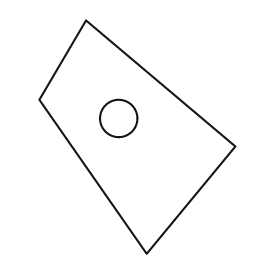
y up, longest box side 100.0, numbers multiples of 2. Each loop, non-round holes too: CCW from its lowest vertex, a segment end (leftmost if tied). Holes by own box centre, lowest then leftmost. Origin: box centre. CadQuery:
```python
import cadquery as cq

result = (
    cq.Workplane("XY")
    .moveTo(4.0, -50.0)
    .lineTo(42.0, -4.0)
    .lineTo(-22.0, 50.0)
    .lineTo(-42.0, 16.0)
    .close()
    .moveTo(-8.0, 8.0)
    .circle(8.0)
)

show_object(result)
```